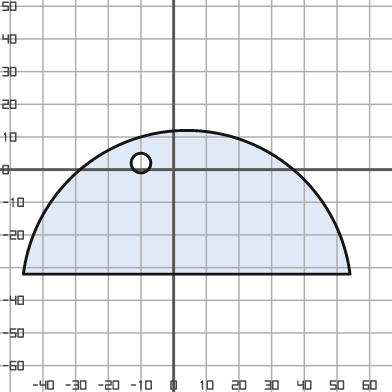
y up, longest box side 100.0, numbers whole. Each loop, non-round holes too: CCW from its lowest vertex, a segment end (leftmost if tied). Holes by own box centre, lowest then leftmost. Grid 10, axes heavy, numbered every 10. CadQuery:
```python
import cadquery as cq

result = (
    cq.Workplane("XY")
    .moveTo(-46.0, -32.0)
    .lineTo(54.0, -32.0)
    .threePointArc((4.0, 12.0), (-46.0, -32.0))
    .close()
    .moveTo(-10.0, 2.0)
    .circle(3.0)
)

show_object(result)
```